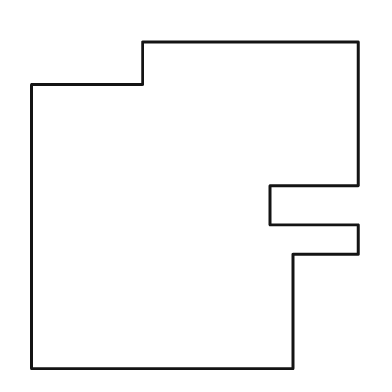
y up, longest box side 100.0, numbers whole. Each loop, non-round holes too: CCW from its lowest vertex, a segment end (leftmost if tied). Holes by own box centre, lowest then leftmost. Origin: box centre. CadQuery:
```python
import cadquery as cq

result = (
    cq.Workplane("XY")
    .moveTo(-50.0, -50.0)
    .lineTo(30.0, -50.0)
    .lineTo(30.0, -15.0)
    .lineTo(50.0, -15.0)
    .lineTo(50.0, -6.0)
    .lineTo(23.0, -6.0)
    .lineTo(23.0, 6.0)
    .lineTo(50.0, 6.0)
    .lineTo(50.0, 50.0)
    .lineTo(-16.0, 50.0)
    .lineTo(-16.0, 37.0)
    .lineTo(-50.0, 37.0)
    .close()
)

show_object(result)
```